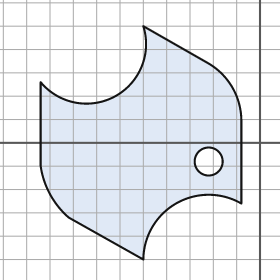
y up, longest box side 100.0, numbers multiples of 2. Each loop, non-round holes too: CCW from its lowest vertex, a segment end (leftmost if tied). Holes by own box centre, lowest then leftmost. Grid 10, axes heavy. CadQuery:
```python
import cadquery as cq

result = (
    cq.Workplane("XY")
    .moveTo(-50.0, -50.0)
    .threePointArc((-36.0, -26.0), (-8.0, -26.0))
    .lineTo(-8.0, 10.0)
    .threePointArc((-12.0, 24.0), (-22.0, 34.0))
    .lineTo(-50.0, 50.0)
    .threePointArc((-62.0, 20.0), (-94.0, 26.0))
    .lineTo(-94.0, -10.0)
    .threePointArc((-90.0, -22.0), (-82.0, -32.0))
    .close()
    .moveTo(-22.0, -8.0)
    .circle(6.0)
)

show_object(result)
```